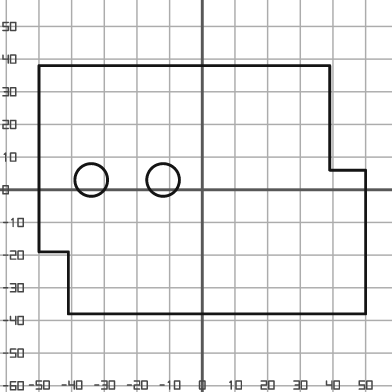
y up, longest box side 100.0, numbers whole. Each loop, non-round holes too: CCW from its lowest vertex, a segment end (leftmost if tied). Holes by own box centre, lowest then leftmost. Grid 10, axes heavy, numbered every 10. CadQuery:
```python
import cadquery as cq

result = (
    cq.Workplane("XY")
    .moveTo(-41.0, -38.0)
    .lineTo(50.0, -38.0)
    .lineTo(50.0, 6.0)
    .lineTo(39.0, 6.0)
    .lineTo(39.0, 38.0)
    .lineTo(-50.0, 38.0)
    .lineTo(-50.0, -19.0)
    .lineTo(-41.0, -19.0)
    .close()
    .moveTo(-34.0, 3.0)
    .circle(5.0)
    .moveTo(-12.0, 3.0)
    .circle(5.0)
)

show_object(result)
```